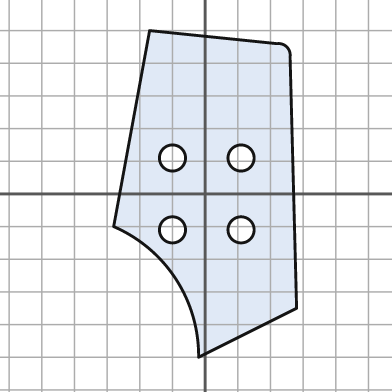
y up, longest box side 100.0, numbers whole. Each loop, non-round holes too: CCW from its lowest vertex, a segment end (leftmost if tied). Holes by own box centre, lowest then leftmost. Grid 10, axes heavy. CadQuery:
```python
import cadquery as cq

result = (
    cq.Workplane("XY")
    .moveTo(-2.0, -50.0)
    .lineTo(28.0, -35.0)
    .lineTo(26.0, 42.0)
    .threePointArc((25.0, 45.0), (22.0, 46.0))
    .lineTo(-17.0, 50.0)
    .lineTo(-28.0, -10.0)
    .threePointArc((-9.0, -26.0), (-2.0, -50.0))
    .close()
    .moveTo(-10.0, -11.0)
    .circle(4.0)
    .moveTo(11.0, -11.0)
    .circle(4.0)
    .moveTo(-10.0, 11.0)
    .circle(4.0)
    .moveTo(11.0, 11.0)
    .circle(4.0)
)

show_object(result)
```